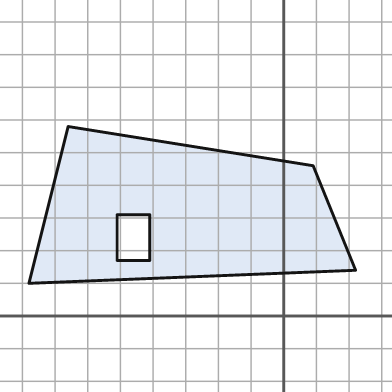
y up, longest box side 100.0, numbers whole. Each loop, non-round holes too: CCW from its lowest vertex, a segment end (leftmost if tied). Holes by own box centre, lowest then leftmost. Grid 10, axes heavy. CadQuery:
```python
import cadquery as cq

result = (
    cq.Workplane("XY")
    .moveTo(-78.0, 10.0)
    .lineTo(22.0, 14.0)
    .lineTo(9.0, 46.0)
    .lineTo(-66.0, 58.0)
    .close()
    .moveTo(-51.0, 17.0)
    .lineTo(-41.0, 17.0)
    .lineTo(-41.0, 31.0)
    .lineTo(-51.0, 31.0)
    .close()
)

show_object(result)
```